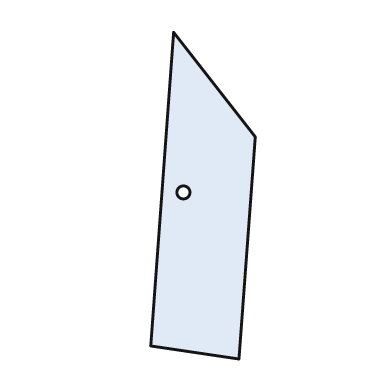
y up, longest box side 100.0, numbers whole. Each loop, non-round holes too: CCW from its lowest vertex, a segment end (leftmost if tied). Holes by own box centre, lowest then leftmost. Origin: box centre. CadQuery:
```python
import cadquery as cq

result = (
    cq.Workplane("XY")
    .moveTo(11.0, -50.0)
    .lineTo(16.0, 18.0)
    .lineTo(-9.0, 50.0)
    .lineTo(-16.0, -46.0)
    .close()
    .moveTo(-6.0, 1.0)
    .circle(2.0)
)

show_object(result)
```